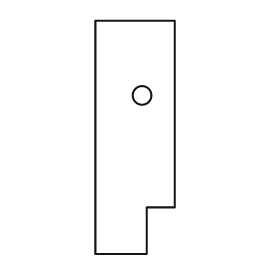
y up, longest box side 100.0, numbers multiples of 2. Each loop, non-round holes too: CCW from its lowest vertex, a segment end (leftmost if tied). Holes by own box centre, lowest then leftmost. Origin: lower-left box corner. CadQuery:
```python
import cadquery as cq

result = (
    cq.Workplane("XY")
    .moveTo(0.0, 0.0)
    .lineTo(22.0, 0.0)
    .lineTo(22.0, 20.0)
    .lineTo(34.0, 20.0)
    .lineTo(34.0, 100.0)
    .lineTo(0.0, 100.0)
    .close()
    .moveTo(20.0, 68.0)
    .circle(4.0)
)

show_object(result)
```